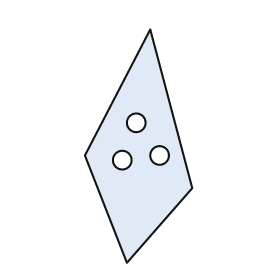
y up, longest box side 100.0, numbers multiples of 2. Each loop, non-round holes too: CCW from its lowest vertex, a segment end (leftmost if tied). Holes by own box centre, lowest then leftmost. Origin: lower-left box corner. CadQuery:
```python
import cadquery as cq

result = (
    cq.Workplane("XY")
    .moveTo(18.0, 0.0)
    .lineTo(46.0, 32.0)
    .lineTo(28.0, 100.0)
    .lineTo(0.0, 46.0)
    .close()
    .moveTo(16.0, 44.0)
    .circle(4.0)
    .moveTo(32.0, 46.0)
    .circle(4.0)
    .moveTo(22.0, 60.0)
    .circle(4.0)
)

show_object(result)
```